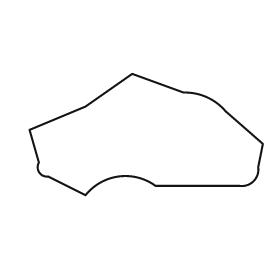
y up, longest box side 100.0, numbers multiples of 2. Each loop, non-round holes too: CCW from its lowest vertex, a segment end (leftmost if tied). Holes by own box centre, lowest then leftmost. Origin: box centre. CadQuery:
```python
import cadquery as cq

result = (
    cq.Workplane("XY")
    .moveTo(-26.0, -26.0)
    .threePointArc((-12.0, -18.0), (4.0, -22.0))
    .lineTo(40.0, -22.0)
    .threePointArc((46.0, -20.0), (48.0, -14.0))
    .lineTo(50.0, -4.0)
    .lineTo(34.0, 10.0)
    .threePointArc((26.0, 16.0), (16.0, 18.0))
    .lineTo(-6.0, 26.0)
    .lineTo(-26.0, 12.0)
    .lineTo(-50.0, 2.0)
    .lineTo(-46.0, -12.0)
    .threePointArc((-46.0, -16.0), (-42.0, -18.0))
    .close()
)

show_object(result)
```